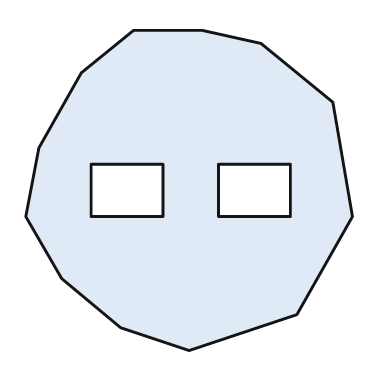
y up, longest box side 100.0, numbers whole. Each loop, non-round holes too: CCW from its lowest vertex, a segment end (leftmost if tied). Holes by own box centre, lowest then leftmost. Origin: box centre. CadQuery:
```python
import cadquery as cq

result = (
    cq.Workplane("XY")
    .moveTo(0.0, -49.0)
    .lineTo(33.0, -38.0)
    .lineTo(50.0, -8.0)
    .lineTo(44.0, 27.0)
    .lineTo(22.0, 45.0)
    .lineTo(4.0, 49.0)
    .lineTo(-17.0, 49.0)
    .lineTo(-33.0, 36.0)
    .lineTo(-46.0, 13.0)
    .lineTo(-50.0, -8.0)
    .lineTo(-39.0, -27.0)
    .lineTo(-21.0, -42.0)
    .close()
    .moveTo(-30.0, -8.0)
    .lineTo(-8.0, -8.0)
    .lineTo(-8.0, 8.0)
    .lineTo(-30.0, 8.0)
    .close()
    .moveTo(9.0, -8.0)
    .lineTo(31.0, -8.0)
    .lineTo(31.0, 8.0)
    .lineTo(9.0, 8.0)
    .close()
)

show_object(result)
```